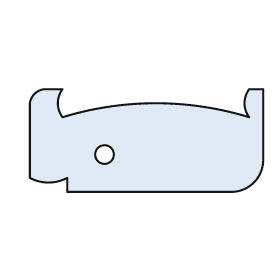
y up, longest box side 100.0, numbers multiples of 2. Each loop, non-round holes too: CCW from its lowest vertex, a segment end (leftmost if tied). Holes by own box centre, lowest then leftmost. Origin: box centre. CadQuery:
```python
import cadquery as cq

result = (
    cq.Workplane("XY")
    .moveTo(-34.0, -22.0)
    .lineTo(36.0, -22.0)
    .threePointArc((46.0, -18.0), (50.0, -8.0))
    .lineTo(50.0, 22.0)
    .lineTo(44.0, 22.0)
    .threePointArc((42.0, 16.0), (44.0, 10.0))
    .threePointArc((4.0, 16.0), (-36.0, 10.0))
    .threePointArc((-38.0, 16.0), (-36.0, 22.0))
    .lineTo(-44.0, 22.0)
    .threePointArc((-48.0, 20.0), (-50.0, 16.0))
    .lineTo(-50.0, -16.0)
    .threePointArc((-42.0, -18.0), (-34.0, -16.0))
    .close()
    .moveTo(-18.0, -6.0)
    .circle(4.0)
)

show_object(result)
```